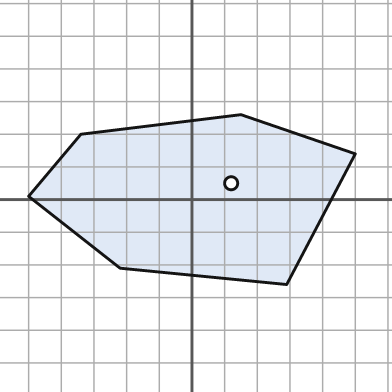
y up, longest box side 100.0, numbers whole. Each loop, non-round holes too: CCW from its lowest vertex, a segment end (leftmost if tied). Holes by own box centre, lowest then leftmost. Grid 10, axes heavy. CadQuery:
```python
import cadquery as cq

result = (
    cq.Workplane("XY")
    .moveTo(29.0, -26.0)
    .lineTo(50.0, 14.0)
    .lineTo(15.0, 26.0)
    .lineTo(-34.0, 20.0)
    .lineTo(-50.0, 1.0)
    .lineTo(-22.0, -21.0)
    .close()
    .moveTo(12.0, 5.0)
    .circle(2.0)
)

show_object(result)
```